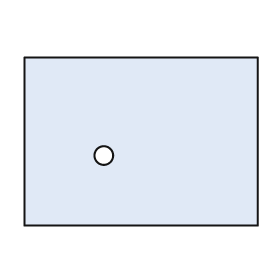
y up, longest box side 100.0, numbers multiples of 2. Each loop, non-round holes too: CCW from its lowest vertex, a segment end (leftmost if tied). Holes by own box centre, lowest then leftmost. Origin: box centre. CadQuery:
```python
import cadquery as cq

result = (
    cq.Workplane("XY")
    .moveTo(-50.0, -36.0)
    .lineTo(50.0, -36.0)
    .lineTo(50.0, 36.0)
    .lineTo(-50.0, 36.0)
    .close()
    .moveTo(-16.0, -6.0)
    .circle(4.0)
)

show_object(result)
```